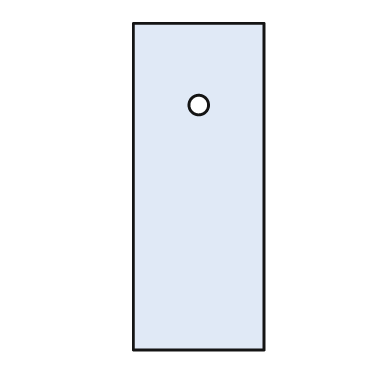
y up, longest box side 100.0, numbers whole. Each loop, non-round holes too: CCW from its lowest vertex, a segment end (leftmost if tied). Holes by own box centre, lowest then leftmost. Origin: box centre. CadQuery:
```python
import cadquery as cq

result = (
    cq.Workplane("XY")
    .moveTo(-20.0, -50.0)
    .lineTo(20.0, -50.0)
    .lineTo(20.0, 50.0)
    .lineTo(-20.0, 50.0)
    .close()
    .moveTo(0.0, 25.0)
    .circle(3.0)
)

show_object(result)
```